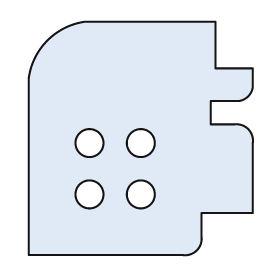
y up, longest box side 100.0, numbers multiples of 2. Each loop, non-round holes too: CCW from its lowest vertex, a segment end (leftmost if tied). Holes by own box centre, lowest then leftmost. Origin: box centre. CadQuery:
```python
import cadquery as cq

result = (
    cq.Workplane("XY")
    .moveTo(-48.0, -50.0)
    .lineTo(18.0, -50.0)
    .threePointArc((24.0, -48.0), (26.0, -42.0))
    .lineTo(26.0, -32.0)
    .lineTo(48.0, -32.0)
    .lineTo(48.0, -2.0)
    .threePointArc((46.0, 4.0), (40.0, 6.0))
    .lineTo(30.0, 6.0)
    .lineTo(30.0, 16.0)
    .lineTo(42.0, 16.0)
    .threePointArc((46.0, 18.0), (48.0, 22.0))
    .lineTo(48.0, 30.0)
    .lineTo(32.0, 30.0)
    .lineTo(32.0, 50.0)
    .lineTo(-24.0, 50.0)
    .threePointArc((-40.0, 42.0), (-48.0, 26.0))
    .close()
    .moveTo(-22.0, -24.0)
    .circle(6.0)
    .moveTo(0.0, -24.0)
    .circle(6.0)
    .moveTo(-22.0, -2.0)
    .circle(6.0)
    .moveTo(0.0, -2.0)
    .circle(6.0)
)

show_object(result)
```